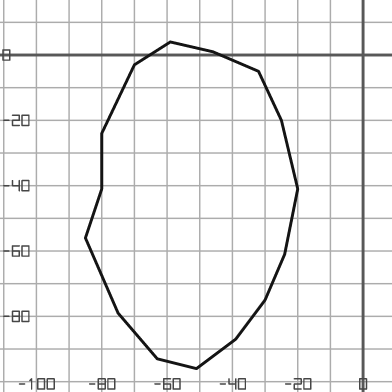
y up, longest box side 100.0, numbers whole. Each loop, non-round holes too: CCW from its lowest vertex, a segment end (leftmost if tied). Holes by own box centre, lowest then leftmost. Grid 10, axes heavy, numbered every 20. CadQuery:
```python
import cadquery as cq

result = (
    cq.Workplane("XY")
    .moveTo(-51.0, -96.0)
    .lineTo(-39.0, -87.0)
    .lineTo(-30.0, -75.0)
    .lineTo(-24.0, -61.0)
    .lineTo(-20.0, -41.0)
    .lineTo(-25.0, -20.0)
    .lineTo(-32.0, -5.0)
    .lineTo(-46.0, 1.0)
    .lineTo(-59.0, 4.0)
    .lineTo(-70.0, -3.0)
    .lineTo(-80.0, -24.0)
    .lineTo(-80.0, -41.0)
    .lineTo(-85.0, -56.0)
    .lineTo(-75.0, -79.0)
    .lineTo(-63.0, -93.0)
    .close()
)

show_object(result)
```